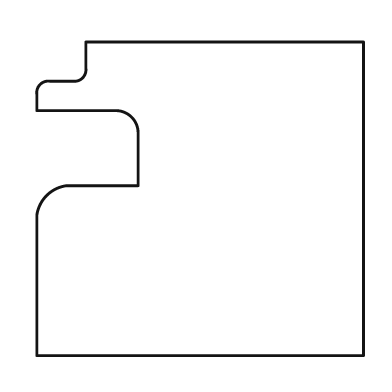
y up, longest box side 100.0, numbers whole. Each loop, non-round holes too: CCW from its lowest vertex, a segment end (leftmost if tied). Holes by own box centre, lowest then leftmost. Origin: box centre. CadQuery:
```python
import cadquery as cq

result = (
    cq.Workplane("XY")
    .moveTo(-50.0, -48.0)
    .lineTo(50.0, -48.0)
    .lineTo(50.0, 48.0)
    .lineTo(-35.0, 48.0)
    .lineTo(-35.0, 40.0)
    .threePointArc((-36.0, 37.0), (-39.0, 36.0))
    .lineTo(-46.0, 36.0)
    .threePointArc((-49.0, 35.0), (-50.0, 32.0))
    .lineTo(-50.0, 27.0)
    .lineTo(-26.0, 27.0)
    .threePointArc((-21.0, 25.0), (-19.0, 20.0))
    .lineTo(-19.0, 4.0)
    .lineTo(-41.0, 4.0)
    .threePointArc((-47.0, 1.0), (-50.0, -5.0))
    .close()
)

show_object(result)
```